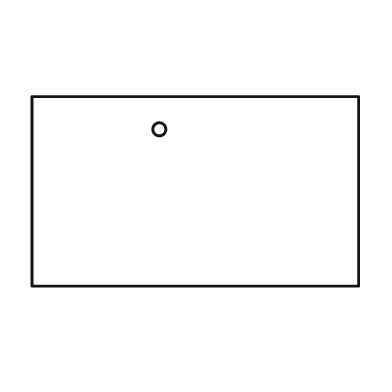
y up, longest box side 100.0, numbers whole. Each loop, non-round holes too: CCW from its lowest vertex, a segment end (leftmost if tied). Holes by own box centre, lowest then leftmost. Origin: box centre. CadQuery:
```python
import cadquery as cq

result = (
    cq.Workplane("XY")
    .moveTo(-50.0, -29.0)
    .lineTo(50.0, -29.0)
    .lineTo(50.0, 29.0)
    .lineTo(-50.0, 29.0)
    .close()
    .moveTo(-11.0, 19.0)
    .circle(2.0)
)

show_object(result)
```